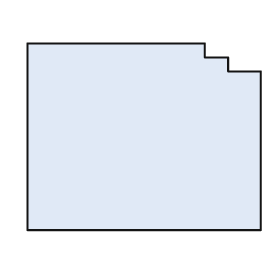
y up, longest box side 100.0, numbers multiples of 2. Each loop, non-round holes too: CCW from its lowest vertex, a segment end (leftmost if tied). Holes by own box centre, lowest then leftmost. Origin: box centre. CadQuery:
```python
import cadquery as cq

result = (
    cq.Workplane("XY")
    .moveTo(-50.0, -40.0)
    .lineTo(50.0, -40.0)
    .lineTo(50.0, 28.0)
    .lineTo(36.0, 28.0)
    .lineTo(36.0, 34.0)
    .lineTo(26.0, 34.0)
    .lineTo(26.0, 40.0)
    .lineTo(-50.0, 40.0)
    .close()
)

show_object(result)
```